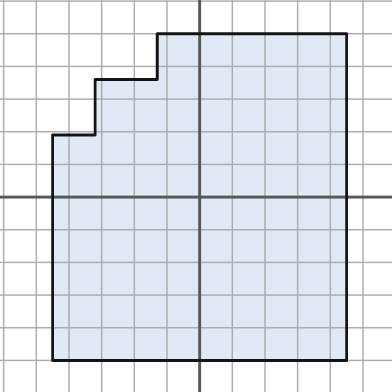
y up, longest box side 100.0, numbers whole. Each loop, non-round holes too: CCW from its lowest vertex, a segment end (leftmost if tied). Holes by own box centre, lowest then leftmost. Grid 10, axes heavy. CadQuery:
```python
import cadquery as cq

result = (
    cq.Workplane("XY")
    .moveTo(-45.0, -50.0)
    .lineTo(45.0, -50.0)
    .lineTo(45.0, 50.0)
    .lineTo(-13.0, 50.0)
    .lineTo(-13.0, 36.0)
    .lineTo(-32.0, 36.0)
    .lineTo(-32.0, 19.0)
    .lineTo(-45.0, 19.0)
    .close()
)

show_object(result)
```